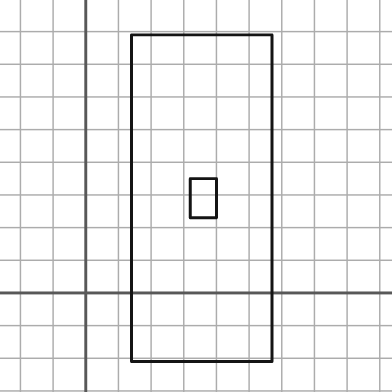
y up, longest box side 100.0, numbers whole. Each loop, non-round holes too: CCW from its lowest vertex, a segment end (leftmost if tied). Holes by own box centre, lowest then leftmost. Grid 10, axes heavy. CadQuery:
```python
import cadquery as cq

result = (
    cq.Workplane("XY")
    .moveTo(14.0, -21.0)
    .lineTo(57.0, -21.0)
    .lineTo(57.0, 79.0)
    .lineTo(14.0, 79.0)
    .close()
    .moveTo(32.0, 23.0)
    .lineTo(40.0, 23.0)
    .lineTo(40.0, 35.0)
    .lineTo(32.0, 35.0)
    .close()
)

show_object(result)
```